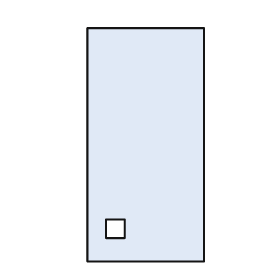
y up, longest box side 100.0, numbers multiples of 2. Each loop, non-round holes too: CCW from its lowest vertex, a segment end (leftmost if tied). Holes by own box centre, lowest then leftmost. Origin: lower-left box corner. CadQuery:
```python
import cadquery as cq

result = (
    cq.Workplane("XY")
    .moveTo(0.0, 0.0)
    .lineTo(50.0, 0.0)
    .lineTo(50.0, 100.0)
    .lineTo(0.0, 100.0)
    .close()
    .moveTo(8.0, 10.0)
    .lineTo(16.0, 10.0)
    .lineTo(16.0, 18.0)
    .lineTo(8.0, 18.0)
    .close()
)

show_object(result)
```